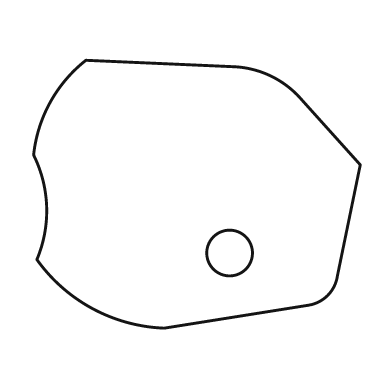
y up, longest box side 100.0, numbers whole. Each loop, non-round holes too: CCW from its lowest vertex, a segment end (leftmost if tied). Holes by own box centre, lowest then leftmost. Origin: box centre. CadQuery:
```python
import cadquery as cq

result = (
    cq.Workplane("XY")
    .moveTo(-10.0, -41.0)
    .lineTo(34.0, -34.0)
    .threePointArc((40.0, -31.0), (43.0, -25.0))
    .lineTo(50.0, 9.0)
    .lineTo(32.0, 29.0)
    .threePointArc((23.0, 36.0), (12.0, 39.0))
    .lineTo(-34.0, 41.0)
    .threePointArc((-45.0, 28.0), (-50.0, 12.0))
    .threePointArc((-46.0, -4.0), (-49.0, -20.0))
    .threePointArc((-32.0, -35.0), (-10.0, -41.0))
    .close()
    .moveTo(10.0, -18.0)
    .circle(7.0)
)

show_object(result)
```